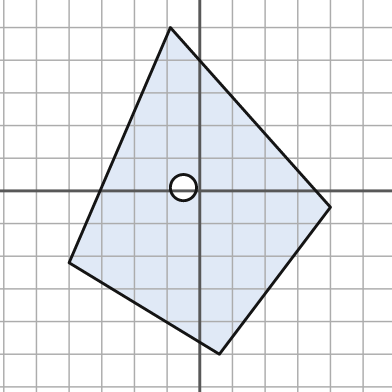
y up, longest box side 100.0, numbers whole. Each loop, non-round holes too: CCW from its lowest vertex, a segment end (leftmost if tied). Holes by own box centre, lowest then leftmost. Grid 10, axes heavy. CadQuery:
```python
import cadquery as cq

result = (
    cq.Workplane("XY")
    .moveTo(6.0, -50.0)
    .lineTo(40.0, -5.0)
    .lineTo(-9.0, 50.0)
    .lineTo(-40.0, -22.0)
    .close()
    .moveTo(-5.0, 1.0)
    .circle(4.0)
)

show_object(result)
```